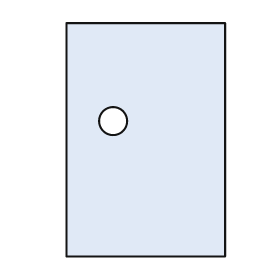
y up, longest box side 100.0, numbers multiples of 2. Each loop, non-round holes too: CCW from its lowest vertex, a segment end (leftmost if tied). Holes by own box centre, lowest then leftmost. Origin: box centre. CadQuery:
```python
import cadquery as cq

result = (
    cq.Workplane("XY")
    .moveTo(-34.0, -50.0)
    .lineTo(34.0, -50.0)
    .lineTo(34.0, 50.0)
    .lineTo(-34.0, 50.0)
    .close()
    .moveTo(-14.0, 8.0)
    .circle(6.0)
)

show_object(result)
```